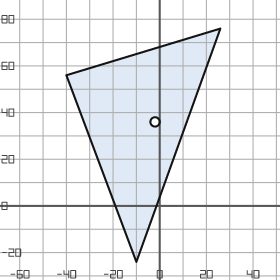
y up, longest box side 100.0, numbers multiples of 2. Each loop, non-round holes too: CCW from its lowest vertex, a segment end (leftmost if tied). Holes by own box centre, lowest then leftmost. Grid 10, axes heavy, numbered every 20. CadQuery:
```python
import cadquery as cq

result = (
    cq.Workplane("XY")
    .moveTo(-10.0, -24.0)
    .lineTo(26.0, 76.0)
    .lineTo(-40.0, 56.0)
    .close()
    .moveTo(-2.0, 36.0)
    .circle(2.0)
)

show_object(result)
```